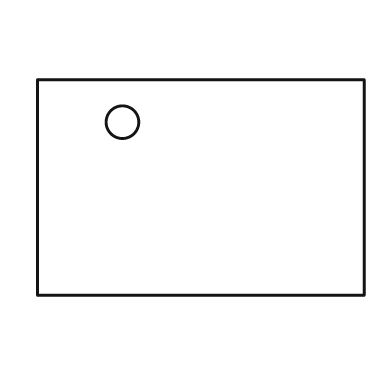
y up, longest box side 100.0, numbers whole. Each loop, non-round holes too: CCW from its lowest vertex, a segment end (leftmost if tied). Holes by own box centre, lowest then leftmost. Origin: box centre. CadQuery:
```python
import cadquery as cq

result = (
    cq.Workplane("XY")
    .moveTo(-50.0, -33.0)
    .lineTo(50.0, -33.0)
    .lineTo(50.0, 33.0)
    .lineTo(-50.0, 33.0)
    .close()
    .moveTo(-24.0, 20.0)
    .circle(5.0)
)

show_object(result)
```